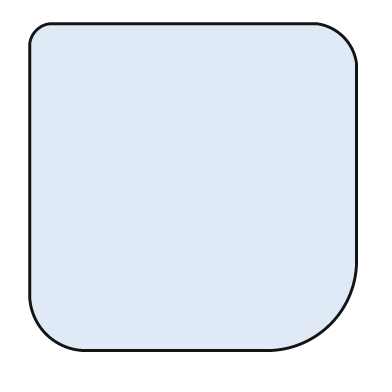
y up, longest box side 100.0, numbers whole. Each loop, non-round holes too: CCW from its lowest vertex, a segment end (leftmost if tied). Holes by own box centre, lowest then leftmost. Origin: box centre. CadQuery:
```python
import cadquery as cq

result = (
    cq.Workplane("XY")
    .moveTo(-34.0, -50.0)
    .lineTo(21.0, -50.0)
    .threePointArc((42.0, -42.0), (50.0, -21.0))
    .lineTo(50.0, 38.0)
    .threePointArc((46.0, 46.0), (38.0, 50.0))
    .lineTo(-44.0, 50.0)
    .threePointArc((-48.0, 48.0), (-50.0, 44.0))
    .lineTo(-50.0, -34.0)
    .threePointArc((-45.0, -45.0), (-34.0, -50.0))
    .close()
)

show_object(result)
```